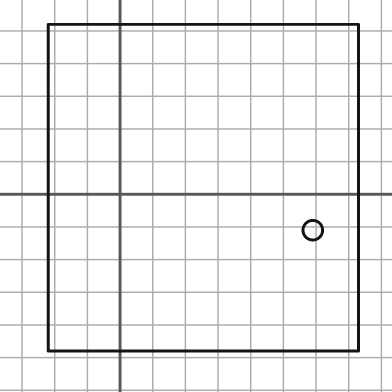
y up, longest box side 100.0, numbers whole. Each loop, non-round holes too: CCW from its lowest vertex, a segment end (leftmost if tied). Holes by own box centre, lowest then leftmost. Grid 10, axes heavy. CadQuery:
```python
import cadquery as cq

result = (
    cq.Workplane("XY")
    .moveTo(-22.0, -48.0)
    .lineTo(73.0, -48.0)
    .lineTo(73.0, 52.0)
    .lineTo(-22.0, 52.0)
    .close()
    .moveTo(59.0, -11.0)
    .circle(3.0)
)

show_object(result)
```